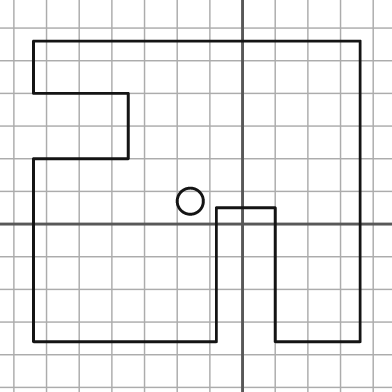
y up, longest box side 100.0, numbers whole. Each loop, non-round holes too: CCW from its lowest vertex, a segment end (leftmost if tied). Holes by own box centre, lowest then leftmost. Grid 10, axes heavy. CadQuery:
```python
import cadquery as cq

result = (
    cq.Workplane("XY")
    .moveTo(-64.0, -36.0)
    .lineTo(-8.0, -36.0)
    .lineTo(-8.0, 5.0)
    .lineTo(10.0, 5.0)
    .lineTo(10.0, -36.0)
    .lineTo(36.0, -36.0)
    .lineTo(36.0, 56.0)
    .lineTo(-64.0, 56.0)
    .lineTo(-64.0, 40.0)
    .lineTo(-35.0, 40.0)
    .lineTo(-35.0, 20.0)
    .lineTo(-64.0, 20.0)
    .close()
    .moveTo(-16.0, 7.0)
    .circle(4.0)
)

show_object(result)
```